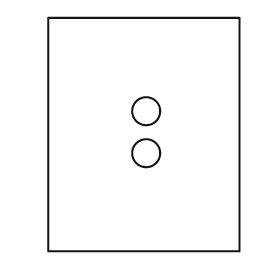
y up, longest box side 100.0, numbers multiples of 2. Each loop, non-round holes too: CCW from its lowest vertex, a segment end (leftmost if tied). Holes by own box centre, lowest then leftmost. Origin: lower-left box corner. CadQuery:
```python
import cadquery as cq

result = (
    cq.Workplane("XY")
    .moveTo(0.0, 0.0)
    .lineTo(82.0, 0.0)
    .lineTo(82.0, 100.0)
    .lineTo(0.0, 100.0)
    .close()
    .moveTo(42.0, 42.0)
    .circle(6.0)
    .moveTo(42.0, 60.0)
    .circle(6.0)
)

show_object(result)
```